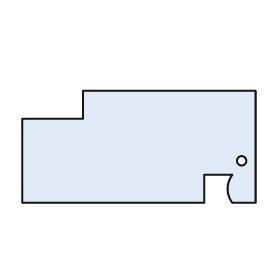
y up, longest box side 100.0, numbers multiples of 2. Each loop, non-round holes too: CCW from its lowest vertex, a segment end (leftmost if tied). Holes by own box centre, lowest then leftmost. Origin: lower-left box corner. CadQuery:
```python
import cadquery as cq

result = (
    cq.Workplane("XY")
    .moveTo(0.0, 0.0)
    .lineTo(78.0, 0.0)
    .lineTo(78.0, 12.0)
    .lineTo(90.0, 12.0)
    .threePointArc((88.0, 6.0), (90.0, 0.0))
    .lineTo(100.0, 0.0)
    .lineTo(100.0, 48.0)
    .lineTo(26.0, 48.0)
    .lineTo(26.0, 36.0)
    .lineTo(0.0, 36.0)
    .close()
    .moveTo(94.0, 18.0)
    .circle(2.0)
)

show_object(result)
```